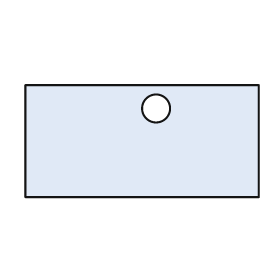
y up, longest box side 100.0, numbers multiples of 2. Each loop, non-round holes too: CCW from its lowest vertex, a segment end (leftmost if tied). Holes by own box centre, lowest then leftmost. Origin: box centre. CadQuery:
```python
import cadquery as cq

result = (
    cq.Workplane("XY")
    .moveTo(-50.0, -24.0)
    .lineTo(50.0, -24.0)
    .lineTo(50.0, 24.0)
    .lineTo(-50.0, 24.0)
    .close()
    .moveTo(6.0, 14.0)
    .circle(6.0)
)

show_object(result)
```